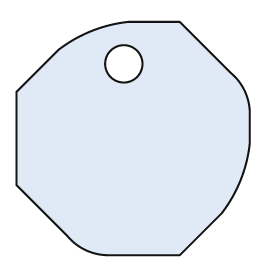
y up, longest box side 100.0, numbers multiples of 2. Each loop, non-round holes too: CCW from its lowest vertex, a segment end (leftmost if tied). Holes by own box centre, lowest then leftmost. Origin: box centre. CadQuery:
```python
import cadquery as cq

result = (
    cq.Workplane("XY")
    .moveTo(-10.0, -50.0)
    .lineTo(20.0, -50.0)
    .lineTo(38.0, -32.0)
    .threePointArc((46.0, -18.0), (50.0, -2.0))
    .lineTo(50.0, 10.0)
    .threePointArc((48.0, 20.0), (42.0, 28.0))
    .lineTo(20.0, 50.0)
    .lineTo(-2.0, 50.0)
    .threePointArc((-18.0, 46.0), (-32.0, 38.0))
    .lineTo(-50.0, 20.0)
    .lineTo(-50.0, -20.0)
    .lineTo(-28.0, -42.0)
    .threePointArc((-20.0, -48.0), (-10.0, -50.0))
    .close()
    .moveTo(-4.0, 32.0)
    .circle(8.0)
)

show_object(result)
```